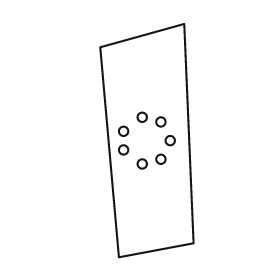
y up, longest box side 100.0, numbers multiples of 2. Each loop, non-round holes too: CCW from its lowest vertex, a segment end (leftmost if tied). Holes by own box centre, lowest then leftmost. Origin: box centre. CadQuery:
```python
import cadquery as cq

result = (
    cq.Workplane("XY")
    .moveTo(-12.0, -50.0)
    .lineTo(20.0, -44.0)
    .lineTo(16.0, 50.0)
    .lineTo(-20.0, 40.0)
    .close()
    .moveTo(-2.0, -10.0)
    .circle(2.0)
    .moveTo(6.0, -8.0)
    .circle(2.0)
    .moveTo(-10.0, -4.0)
    .circle(2.0)
    .moveTo(10.0, 0.0)
    .circle(2.0)
    .moveTo(-10.0, 4.0)
    .circle(2.0)
    .moveTo(6.0, 8.0)
    .circle(2.0)
    .moveTo(-2.0, 10.0)
    .circle(2.0)
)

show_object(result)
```